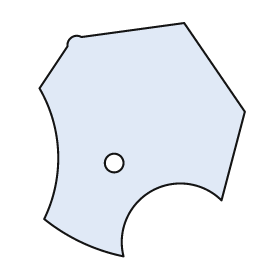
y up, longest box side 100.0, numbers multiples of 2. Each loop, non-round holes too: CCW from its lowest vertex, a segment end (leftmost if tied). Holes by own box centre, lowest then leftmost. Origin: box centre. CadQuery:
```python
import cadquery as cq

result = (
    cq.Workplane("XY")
    .moveTo(-8.0, -50.0)
    .threePointArc((4.0, -22.0), (34.0, -26.0))
    .lineTo(44.0, 12.0)
    .lineTo(18.0, 50.0)
    .lineTo(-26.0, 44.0)
    .threePointArc((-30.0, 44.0), (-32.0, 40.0))
    .lineTo(-44.0, 22.0)
    .threePointArc((-36.0, -6.0), (-42.0, -34.0))
    .threePointArc((-26.0, -44.0), (-8.0, -50.0))
    .close()
    .moveTo(-12.0, -10.0)
    .circle(4.0)
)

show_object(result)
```